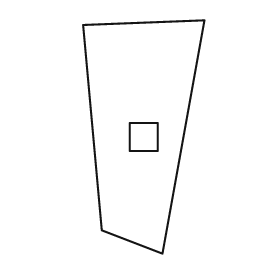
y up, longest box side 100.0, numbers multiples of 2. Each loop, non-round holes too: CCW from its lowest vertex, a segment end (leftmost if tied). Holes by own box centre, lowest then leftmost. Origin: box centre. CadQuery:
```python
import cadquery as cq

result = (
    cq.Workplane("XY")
    .moveTo(8.0, -50.0)
    .lineTo(26.0, 50.0)
    .lineTo(-26.0, 48.0)
    .lineTo(-18.0, -40.0)
    .close()
    .moveTo(-6.0, -6.0)
    .lineTo(6.0, -6.0)
    .lineTo(6.0, 6.0)
    .lineTo(-6.0, 6.0)
    .close()
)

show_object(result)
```